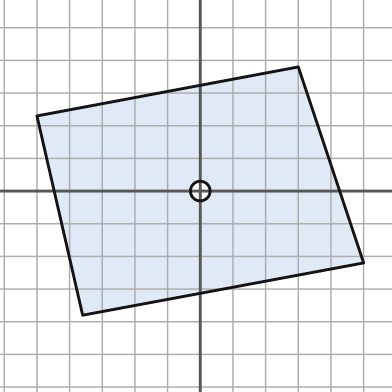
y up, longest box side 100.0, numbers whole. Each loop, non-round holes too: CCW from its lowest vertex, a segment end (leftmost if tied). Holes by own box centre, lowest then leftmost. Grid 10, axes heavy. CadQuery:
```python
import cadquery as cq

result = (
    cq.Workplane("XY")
    .moveTo(-36.0, -38.0)
    .lineTo(50.0, -22.0)
    .lineTo(30.0, 38.0)
    .lineTo(-50.0, 23.0)
    .close()
    .moveTo(0.0, 0.0)
    .circle(3.0)
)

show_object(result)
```